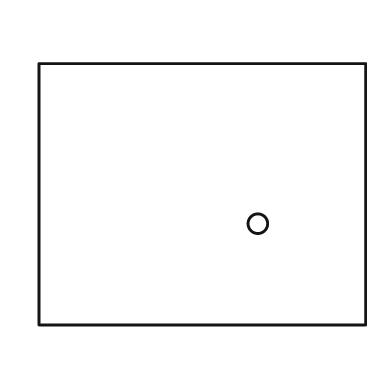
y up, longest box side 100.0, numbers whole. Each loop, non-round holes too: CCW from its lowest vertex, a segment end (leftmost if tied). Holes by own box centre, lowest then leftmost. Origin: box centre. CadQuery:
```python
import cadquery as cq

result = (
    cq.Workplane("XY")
    .moveTo(-50.0, -40.0)
    .lineTo(50.0, -40.0)
    .lineTo(50.0, 40.0)
    .lineTo(-50.0, 40.0)
    .close()
    .moveTo(17.0, -9.0)
    .circle(3.0)
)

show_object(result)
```